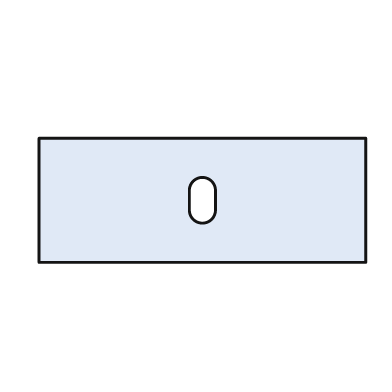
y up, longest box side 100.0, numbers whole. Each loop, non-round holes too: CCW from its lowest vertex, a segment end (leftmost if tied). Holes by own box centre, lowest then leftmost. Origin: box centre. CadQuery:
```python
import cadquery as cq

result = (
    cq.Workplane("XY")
    .moveTo(-50.0, -19.0)
    .lineTo(50.0, -19.0)
    .lineTo(50.0, 19.0)
    .lineTo(-50.0, 19.0)
    .close()
    .moveTo(-4.0, -3.0)
    .threePointArc((0.0, -7.0), (4.0, -3.0))
    .lineTo(4.0, 3.0)
    .threePointArc((0.0, 7.0), (-4.0, 3.0))
    .close()
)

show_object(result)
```